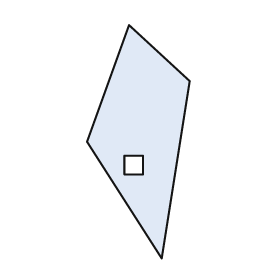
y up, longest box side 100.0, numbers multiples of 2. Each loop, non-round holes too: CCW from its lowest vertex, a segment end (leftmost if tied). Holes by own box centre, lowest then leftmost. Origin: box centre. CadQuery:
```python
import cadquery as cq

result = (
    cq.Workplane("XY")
    .moveTo(10.0, -50.0)
    .lineTo(22.0, 26.0)
    .lineTo(-4.0, 50.0)
    .lineTo(-22.0, 0.0)
    .close()
    .moveTo(-6.0, -14.0)
    .lineTo(2.0, -14.0)
    .lineTo(2.0, -6.0)
    .lineTo(-6.0, -6.0)
    .close()
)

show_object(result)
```